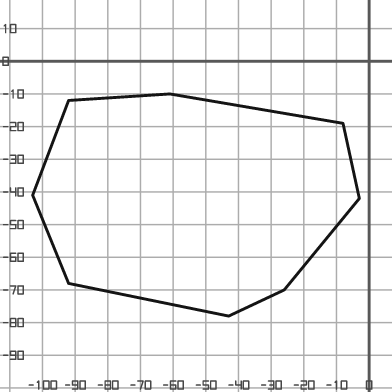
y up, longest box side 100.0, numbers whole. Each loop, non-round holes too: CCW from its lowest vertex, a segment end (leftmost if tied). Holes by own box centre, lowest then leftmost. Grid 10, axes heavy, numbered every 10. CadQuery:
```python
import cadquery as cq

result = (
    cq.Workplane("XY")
    .moveTo(-43.0, -78.0)
    .lineTo(-26.0, -70.0)
    .lineTo(-3.0, -42.0)
    .lineTo(-8.0, -19.0)
    .lineTo(-61.0, -10.0)
    .lineTo(-92.0, -12.0)
    .lineTo(-103.0, -41.0)
    .lineTo(-92.0, -68.0)
    .close()
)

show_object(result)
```